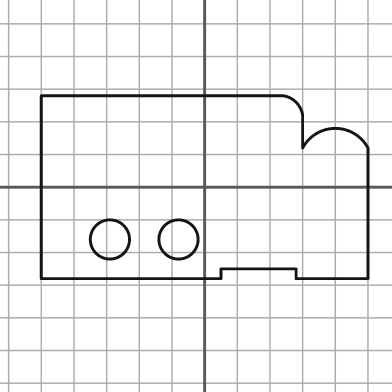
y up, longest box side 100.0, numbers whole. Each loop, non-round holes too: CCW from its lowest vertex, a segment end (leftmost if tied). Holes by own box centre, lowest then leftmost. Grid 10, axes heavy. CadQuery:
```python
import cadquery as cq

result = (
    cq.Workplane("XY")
    .moveTo(-50.0, -28.0)
    .lineTo(5.0, -28.0)
    .lineTo(5.0, -25.0)
    .lineTo(28.0, -25.0)
    .lineTo(28.0, -28.0)
    .lineTo(50.0, -28.0)
    .lineTo(50.0, 12.0)
    .threePointArc((40.0, 18.0), (30.0, 12.0))
    .lineTo(30.0, 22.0)
    .threePointArc((28.0, 26.0), (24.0, 28.0))
    .lineTo(-50.0, 28.0)
    .close()
    .moveTo(-29.0, -16.0)
    .circle(6.0)
    .moveTo(-8.0, -16.0)
    .circle(6.0)
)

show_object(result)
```